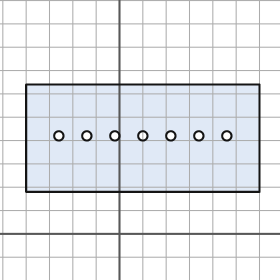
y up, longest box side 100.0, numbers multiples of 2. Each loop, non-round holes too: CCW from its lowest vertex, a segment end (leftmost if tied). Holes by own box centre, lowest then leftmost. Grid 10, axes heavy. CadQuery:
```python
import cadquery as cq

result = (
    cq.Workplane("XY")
    .moveTo(-40.0, 18.0)
    .lineTo(60.0, 18.0)
    .lineTo(60.0, 64.0)
    .lineTo(-40.0, 64.0)
    .close()
    .moveTo(-26.0, 42.0)
    .circle(2.0)
    .moveTo(-14.0, 42.0)
    .circle(2.0)
    .moveTo(-2.0, 42.0)
    .circle(2.0)
    .moveTo(10.0, 42.0)
    .circle(2.0)
    .moveTo(22.0, 42.0)
    .circle(2.0)
    .moveTo(34.0, 42.0)
    .circle(2.0)
    .moveTo(46.0, 42.0)
    .circle(2.0)
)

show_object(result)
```